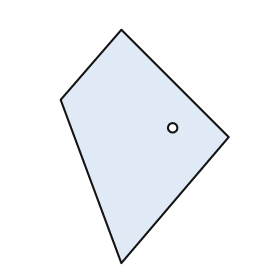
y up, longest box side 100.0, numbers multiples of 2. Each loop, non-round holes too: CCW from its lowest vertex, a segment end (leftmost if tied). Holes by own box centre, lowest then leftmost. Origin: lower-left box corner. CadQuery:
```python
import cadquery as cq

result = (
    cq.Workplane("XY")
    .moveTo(26.0, 0.0)
    .lineTo(72.0, 54.0)
    .lineTo(26.0, 100.0)
    .lineTo(0.0, 70.0)
    .close()
    .moveTo(48.0, 58.0)
    .circle(2.0)
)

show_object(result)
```